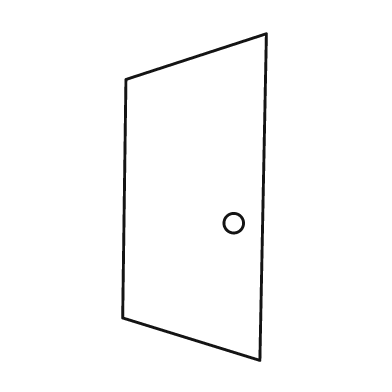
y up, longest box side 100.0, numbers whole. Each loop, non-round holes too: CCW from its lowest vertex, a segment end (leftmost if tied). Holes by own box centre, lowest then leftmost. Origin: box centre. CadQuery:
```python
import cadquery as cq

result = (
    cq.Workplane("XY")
    .moveTo(20.0, -50.0)
    .lineTo(22.0, 50.0)
    .lineTo(-21.0, 36.0)
    .lineTo(-22.0, -37.0)
    .close()
    .moveTo(12.0, -8.0)
    .circle(3.0)
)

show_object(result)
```